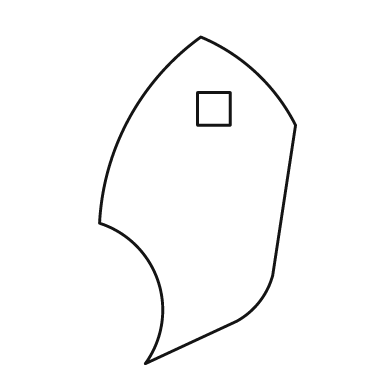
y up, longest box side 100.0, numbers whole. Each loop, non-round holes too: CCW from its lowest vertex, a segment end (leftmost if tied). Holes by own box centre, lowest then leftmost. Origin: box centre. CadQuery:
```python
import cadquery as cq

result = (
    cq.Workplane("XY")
    .moveTo(-16.0, -50.0)
    .lineTo(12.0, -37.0)
    .threePointArc((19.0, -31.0), (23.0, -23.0))
    .lineTo(30.0, 23.0)
    .threePointArc((18.0, 39.0), (1.0, 50.0))
    .threePointArc((-21.0, 25.0), (-30.0, -7.0))
    .threePointArc((-12.0, -25.0), (-16.0, -50.0))
    .close()
    .moveTo(0.0, 23.0)
    .lineTo(10.0, 23.0)
    .lineTo(10.0, 33.0)
    .lineTo(0.0, 33.0)
    .close()
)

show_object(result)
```